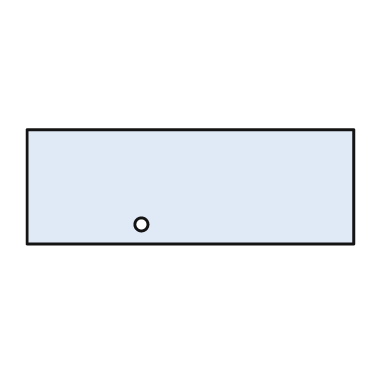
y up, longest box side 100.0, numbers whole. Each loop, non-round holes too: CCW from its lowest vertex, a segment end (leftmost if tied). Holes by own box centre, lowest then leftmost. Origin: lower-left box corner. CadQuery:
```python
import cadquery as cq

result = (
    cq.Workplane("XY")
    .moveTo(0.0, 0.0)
    .lineTo(100.0, 0.0)
    .lineTo(100.0, 35.0)
    .lineTo(0.0, 35.0)
    .close()
    .moveTo(35.0, 6.0)
    .circle(2.0)
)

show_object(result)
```